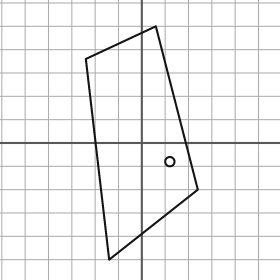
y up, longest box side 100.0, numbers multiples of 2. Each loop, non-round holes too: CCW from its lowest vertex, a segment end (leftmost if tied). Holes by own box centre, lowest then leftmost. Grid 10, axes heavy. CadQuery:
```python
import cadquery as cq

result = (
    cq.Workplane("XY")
    .moveTo(-14.0, -50.0)
    .lineTo(24.0, -20.0)
    .lineTo(6.0, 50.0)
    .lineTo(-24.0, 36.0)
    .close()
    .moveTo(12.0, -8.0)
    .circle(2.0)
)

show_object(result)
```